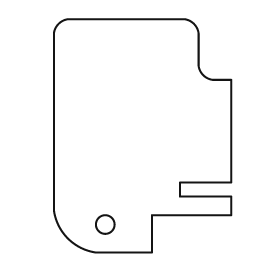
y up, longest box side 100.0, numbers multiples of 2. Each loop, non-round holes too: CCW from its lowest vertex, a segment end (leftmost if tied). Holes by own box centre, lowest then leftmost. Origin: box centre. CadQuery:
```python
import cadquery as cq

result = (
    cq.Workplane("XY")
    .moveTo(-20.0, -50.0)
    .lineTo(4.0, -50.0)
    .lineTo(4.0, -34.0)
    .lineTo(38.0, -34.0)
    .lineTo(38.0, -26.0)
    .lineTo(16.0, -26.0)
    .lineTo(16.0, -20.0)
    .lineTo(38.0, -20.0)
    .lineTo(38.0, 24.0)
    .lineTo(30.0, 24.0)
    .threePointArc((26.0, 26.0), (24.0, 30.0))
    .lineTo(24.0, 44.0)
    .threePointArc((22.0, 48.0), (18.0, 50.0))
    .lineTo(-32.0, 50.0)
    .threePointArc((-36.0, 48.0), (-38.0, 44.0))
    .lineTo(-38.0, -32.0)
    .threePointArc((-32.0, -44.0), (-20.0, -50.0))
    .close()
    .moveTo(-16.0, -38.0)
    .circle(4.0)
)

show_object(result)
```